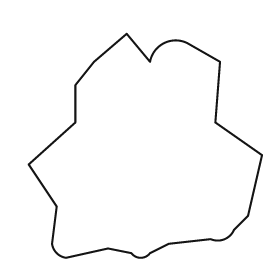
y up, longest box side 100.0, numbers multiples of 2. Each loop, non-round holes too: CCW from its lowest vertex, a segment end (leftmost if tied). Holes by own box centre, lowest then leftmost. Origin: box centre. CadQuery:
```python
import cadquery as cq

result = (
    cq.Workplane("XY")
    .moveTo(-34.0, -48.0)
    .lineTo(-16.0, -44.0)
    .lineTo(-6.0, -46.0)
    .threePointArc((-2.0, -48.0), (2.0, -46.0))
    .lineTo(10.0, -42.0)
    .lineTo(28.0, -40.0)
    .threePointArc((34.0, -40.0), (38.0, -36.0))
    .lineTo(44.0, -30.0)
    .lineTo(50.0, -4.0)
    .lineTo(30.0, 10.0)
    .lineTo(32.0, 36.0)
    .lineTo(18.0, 44.0)
    .threePointArc((8.0, 44.0), (2.0, 36.0))
    .lineTo(-8.0, 48.0)
    .lineTo(-22.0, 36.0)
    .lineTo(-30.0, 26.0)
    .lineTo(-30.0, 10.0)
    .lineTo(-50.0, -8.0)
    .lineTo(-38.0, -26.0)
    .lineTo(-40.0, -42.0)
    .threePointArc((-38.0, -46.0), (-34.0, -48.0))
    .close()
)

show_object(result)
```